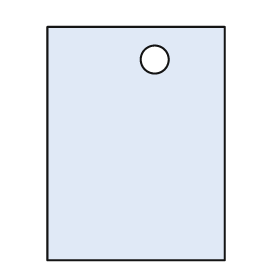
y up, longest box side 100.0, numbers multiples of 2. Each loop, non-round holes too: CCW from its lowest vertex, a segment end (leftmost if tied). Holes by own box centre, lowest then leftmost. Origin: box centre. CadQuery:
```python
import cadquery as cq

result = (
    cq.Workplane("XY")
    .moveTo(-38.0, -50.0)
    .lineTo(38.0, -50.0)
    .lineTo(38.0, 50.0)
    .lineTo(-38.0, 50.0)
    .close()
    .moveTo(8.0, 36.0)
    .circle(6.0)
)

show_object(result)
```